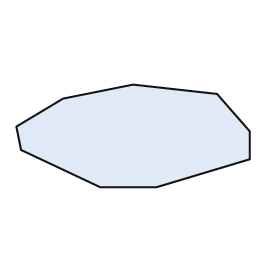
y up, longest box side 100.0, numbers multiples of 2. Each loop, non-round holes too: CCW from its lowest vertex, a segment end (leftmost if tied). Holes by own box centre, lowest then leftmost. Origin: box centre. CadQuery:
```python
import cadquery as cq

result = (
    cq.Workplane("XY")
    .moveTo(-14.0, -22.0)
    .lineTo(10.0, -22.0)
    .lineTo(50.0, -10.0)
    .lineTo(50.0, 2.0)
    .lineTo(36.0, 18.0)
    .lineTo(0.0, 22.0)
    .lineTo(-30.0, 16.0)
    .lineTo(-50.0, 4.0)
    .lineTo(-48.0, -6.0)
    .close()
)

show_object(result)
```